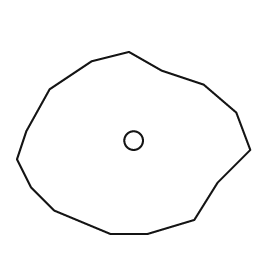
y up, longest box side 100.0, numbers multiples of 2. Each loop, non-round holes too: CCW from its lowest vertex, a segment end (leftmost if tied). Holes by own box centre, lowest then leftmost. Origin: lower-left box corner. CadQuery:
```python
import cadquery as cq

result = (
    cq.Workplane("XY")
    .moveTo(40.0, 0.0)
    .lineTo(56.0, 0.0)
    .lineTo(76.0, 6.0)
    .lineTo(86.0, 22.0)
    .lineTo(100.0, 36.0)
    .lineTo(94.0, 52.0)
    .lineTo(80.0, 64.0)
    .lineTo(62.0, 70.0)
    .lineTo(48.0, 78.0)
    .lineTo(32.0, 74.0)
    .lineTo(14.0, 62.0)
    .lineTo(4.0, 44.0)
    .lineTo(0.0, 32.0)
    .lineTo(6.0, 20.0)
    .lineTo(16.0, 10.0)
    .close()
    .moveTo(50.0, 40.0)
    .circle(4.0)
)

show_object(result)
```